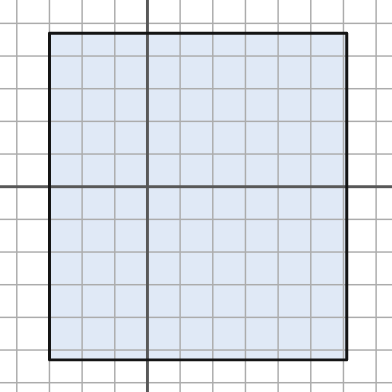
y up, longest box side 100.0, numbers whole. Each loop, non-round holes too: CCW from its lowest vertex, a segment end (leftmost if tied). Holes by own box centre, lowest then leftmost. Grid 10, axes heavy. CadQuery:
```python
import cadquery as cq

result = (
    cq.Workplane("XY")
    .moveTo(-30.0, -53.0)
    .lineTo(61.0, -53.0)
    .lineTo(61.0, 47.0)
    .lineTo(-30.0, 47.0)
    .close()
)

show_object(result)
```